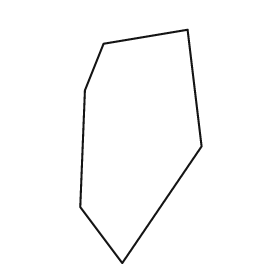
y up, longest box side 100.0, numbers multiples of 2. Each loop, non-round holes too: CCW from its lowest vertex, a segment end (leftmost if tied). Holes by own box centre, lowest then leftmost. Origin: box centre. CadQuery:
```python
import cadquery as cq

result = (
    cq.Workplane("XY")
    .moveTo(-8.0, -50.0)
    .lineTo(26.0, 0.0)
    .lineTo(20.0, 50.0)
    .lineTo(-16.0, 44.0)
    .lineTo(-24.0, 24.0)
    .lineTo(-26.0, -26.0)
    .close()
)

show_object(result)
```